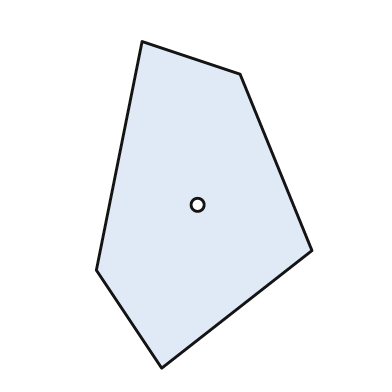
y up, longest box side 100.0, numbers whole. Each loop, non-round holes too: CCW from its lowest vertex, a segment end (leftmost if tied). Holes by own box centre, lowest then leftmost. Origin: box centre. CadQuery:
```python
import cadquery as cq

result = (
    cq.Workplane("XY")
    .moveTo(-13.0, -50.0)
    .lineTo(33.0, -14.0)
    .lineTo(11.0, 40.0)
    .lineTo(-19.0, 50.0)
    .lineTo(-33.0, -20.0)
    .close()
    .moveTo(-2.0, 0.0)
    .circle(2.0)
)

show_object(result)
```